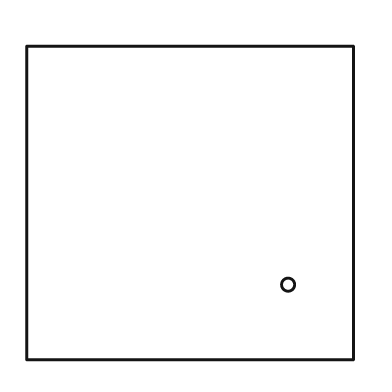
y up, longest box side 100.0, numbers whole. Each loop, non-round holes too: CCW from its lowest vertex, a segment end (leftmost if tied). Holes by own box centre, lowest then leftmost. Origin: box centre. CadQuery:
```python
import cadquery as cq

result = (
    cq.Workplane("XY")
    .moveTo(-50.0, -48.0)
    .lineTo(50.0, -48.0)
    .lineTo(50.0, 48.0)
    .lineTo(-50.0, 48.0)
    .close()
    .moveTo(30.0, -25.0)
    .circle(2.0)
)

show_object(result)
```